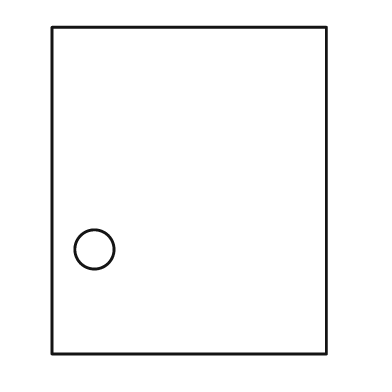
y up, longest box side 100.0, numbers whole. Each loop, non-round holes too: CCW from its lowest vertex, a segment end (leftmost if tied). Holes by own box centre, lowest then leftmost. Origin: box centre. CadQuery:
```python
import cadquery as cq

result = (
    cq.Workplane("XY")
    .moveTo(-42.0, -50.0)
    .lineTo(42.0, -50.0)
    .lineTo(42.0, 50.0)
    .lineTo(-42.0, 50.0)
    .close()
    .moveTo(-29.0, -18.0)
    .circle(6.0)
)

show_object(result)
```